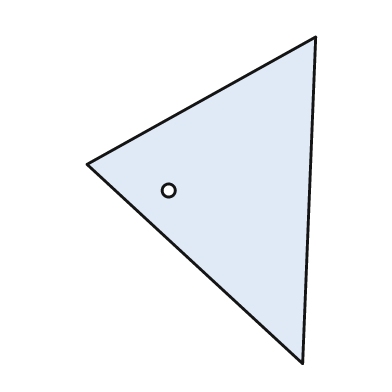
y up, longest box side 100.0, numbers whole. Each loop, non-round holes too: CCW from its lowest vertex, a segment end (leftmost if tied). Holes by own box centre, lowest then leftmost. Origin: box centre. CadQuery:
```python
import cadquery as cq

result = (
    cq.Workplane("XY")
    .moveTo(31.0, -50.0)
    .lineTo(35.0, 50.0)
    .lineTo(-35.0, 11.0)
    .close()
    .moveTo(-10.0, 3.0)
    .circle(2.0)
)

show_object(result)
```